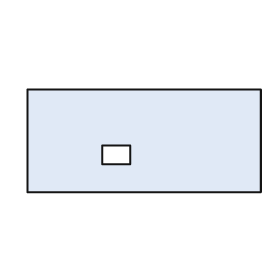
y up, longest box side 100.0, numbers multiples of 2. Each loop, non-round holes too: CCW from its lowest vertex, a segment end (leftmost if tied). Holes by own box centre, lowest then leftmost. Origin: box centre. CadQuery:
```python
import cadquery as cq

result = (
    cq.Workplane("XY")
    .moveTo(-50.0, -22.0)
    .lineTo(50.0, -22.0)
    .lineTo(50.0, 22.0)
    .lineTo(-50.0, 22.0)
    .close()
    .moveTo(-18.0, -10.0)
    .lineTo(-6.0, -10.0)
    .lineTo(-6.0, -2.0)
    .lineTo(-18.0, -2.0)
    .close()
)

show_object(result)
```